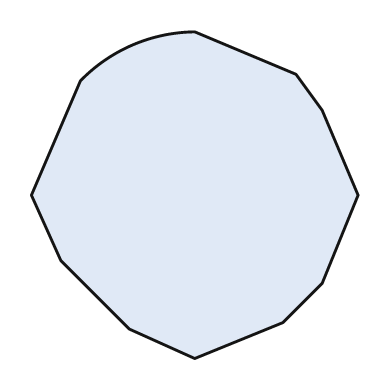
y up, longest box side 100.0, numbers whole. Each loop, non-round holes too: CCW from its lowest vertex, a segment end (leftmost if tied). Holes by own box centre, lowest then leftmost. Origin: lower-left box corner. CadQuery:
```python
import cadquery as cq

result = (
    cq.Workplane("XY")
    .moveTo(50.0, 0.0)
    .lineTo(77.0, 11.0)
    .lineTo(89.0, 23.0)
    .lineTo(100.0, 50.0)
    .lineTo(89.0, 76.0)
    .lineTo(81.0, 87.0)
    .lineTo(50.0, 100.0)
    .threePointArc((31.0, 96.0), (15.0, 85.0))
    .lineTo(0.0, 50.0)
    .lineTo(9.0, 30.0)
    .lineTo(30.0, 9.0)
    .close()
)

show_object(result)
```